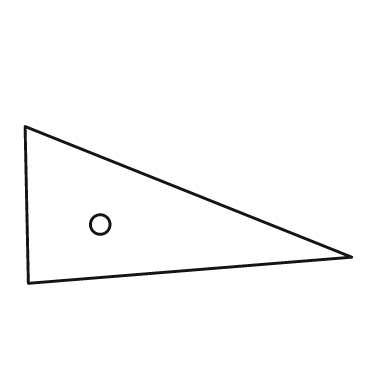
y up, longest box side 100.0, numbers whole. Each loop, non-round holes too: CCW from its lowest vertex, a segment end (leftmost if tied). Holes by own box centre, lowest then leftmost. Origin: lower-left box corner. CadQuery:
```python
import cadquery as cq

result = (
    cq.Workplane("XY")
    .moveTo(1.0, 0.0)
    .lineTo(100.0, 8.0)
    .lineTo(0.0, 48.0)
    .close()
    .moveTo(23.0, 18.0)
    .circle(3.0)
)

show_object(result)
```